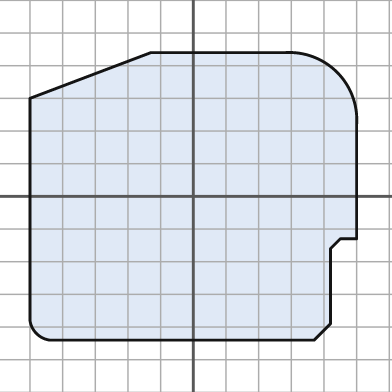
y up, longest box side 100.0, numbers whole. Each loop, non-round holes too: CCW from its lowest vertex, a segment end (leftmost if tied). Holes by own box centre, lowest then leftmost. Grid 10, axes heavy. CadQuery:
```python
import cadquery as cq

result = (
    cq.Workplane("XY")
    .moveTo(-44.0, -44.0)
    .lineTo(37.0, -44.0)
    .lineTo(42.0, -39.0)
    .lineTo(42.0, -16.0)
    .lineTo(45.0, -13.0)
    .lineTo(50.0, -13.0)
    .lineTo(50.0, 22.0)
    .threePointArc((44.0, 38.0), (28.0, 44.0))
    .lineTo(-13.0, 44.0)
    .lineTo(-50.0, 30.0)
    .lineTo(-50.0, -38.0)
    .threePointArc((-48.0, -42.0), (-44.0, -44.0))
    .close()
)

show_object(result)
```